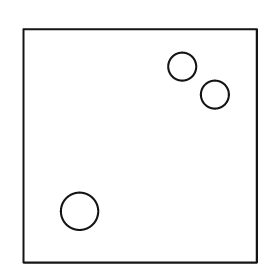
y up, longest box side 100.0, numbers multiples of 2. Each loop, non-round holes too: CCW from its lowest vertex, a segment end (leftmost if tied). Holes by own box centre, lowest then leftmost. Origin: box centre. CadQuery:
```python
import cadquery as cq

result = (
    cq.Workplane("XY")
    .moveTo(-50.0, -50.0)
    .lineTo(50.0, -50.0)
    .lineTo(50.0, 50.0)
    .lineTo(-50.0, 50.0)
    .close()
    .moveTo(-26.0, -28.0)
    .circle(8.0)
    .moveTo(32.0, 22.0)
    .circle(6.0)
    .moveTo(18.0, 34.0)
    .circle(6.0)
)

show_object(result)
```